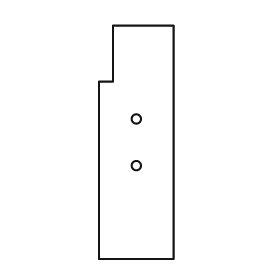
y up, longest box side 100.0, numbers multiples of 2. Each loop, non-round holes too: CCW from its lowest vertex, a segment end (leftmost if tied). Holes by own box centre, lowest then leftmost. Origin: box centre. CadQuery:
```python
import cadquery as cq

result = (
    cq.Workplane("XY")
    .moveTo(-16.0, -50.0)
    .lineTo(16.0, -50.0)
    .lineTo(16.0, 50.0)
    .lineTo(-10.0, 50.0)
    .lineTo(-10.0, 26.0)
    .lineTo(-16.0, 26.0)
    .close()
    .moveTo(0.0, -10.0)
    .circle(2.0)
    .moveTo(0.0, 10.0)
    .circle(2.0)
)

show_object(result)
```